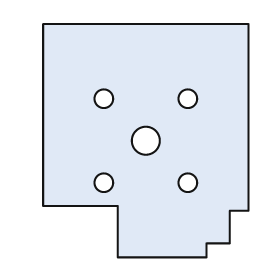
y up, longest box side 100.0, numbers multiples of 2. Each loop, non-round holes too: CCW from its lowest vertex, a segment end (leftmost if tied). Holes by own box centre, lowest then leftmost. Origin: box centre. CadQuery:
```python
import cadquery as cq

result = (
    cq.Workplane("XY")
    .moveTo(-12.0, -50.0)
    .lineTo(26.0, -50.0)
    .lineTo(26.0, -44.0)
    .lineTo(36.0, -44.0)
    .lineTo(36.0, -30.0)
    .lineTo(44.0, -30.0)
    .lineTo(44.0, 50.0)
    .lineTo(-44.0, 50.0)
    .lineTo(-44.0, -28.0)
    .lineTo(-12.0, -28.0)
    .close()
    .moveTo(-18.0, -18.0)
    .circle(4.0)
    .moveTo(18.0, -18.0)
    .circle(4.0)
    .moveTo(0.0, 0.0)
    .circle(6.0)
    .moveTo(-18.0, 18.0)
    .circle(4.0)
    .moveTo(18.0, 18.0)
    .circle(4.0)
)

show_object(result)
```